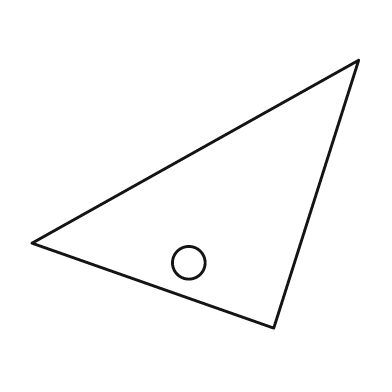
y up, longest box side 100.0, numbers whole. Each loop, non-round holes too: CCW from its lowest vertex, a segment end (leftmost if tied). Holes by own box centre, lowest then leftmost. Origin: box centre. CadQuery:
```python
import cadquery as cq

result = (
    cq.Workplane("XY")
    .moveTo(24.0, -41.0)
    .lineTo(50.0, 41.0)
    .lineTo(-50.0, -15.0)
    .close()
    .moveTo(-2.0, -21.0)
    .circle(5.0)
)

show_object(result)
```